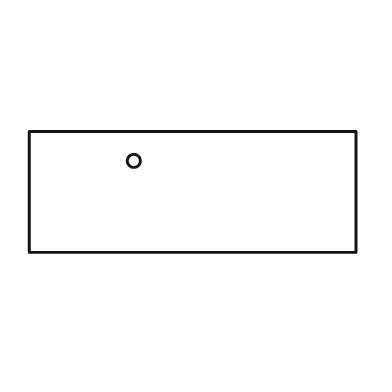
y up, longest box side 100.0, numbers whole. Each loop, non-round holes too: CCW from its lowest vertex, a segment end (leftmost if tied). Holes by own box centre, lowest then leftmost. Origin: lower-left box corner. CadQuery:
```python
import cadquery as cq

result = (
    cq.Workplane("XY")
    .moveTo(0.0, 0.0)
    .lineTo(100.0, 0.0)
    .lineTo(100.0, 37.0)
    .lineTo(0.0, 37.0)
    .close()
    .moveTo(32.0, 28.0)
    .circle(2.0)
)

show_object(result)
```